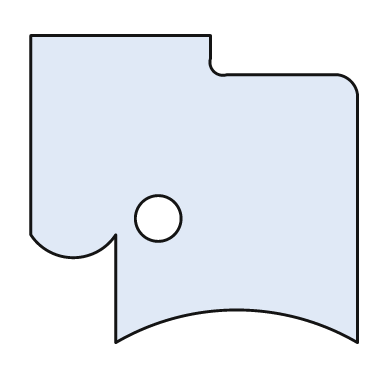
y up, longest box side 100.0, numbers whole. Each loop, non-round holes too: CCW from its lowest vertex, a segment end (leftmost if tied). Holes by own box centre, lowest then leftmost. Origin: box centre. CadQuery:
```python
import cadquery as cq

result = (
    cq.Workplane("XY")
    .moveTo(-24.0, -47.0)
    .threePointArc((13.0, -37.0), (50.0, -47.0))
    .lineTo(50.0, 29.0)
    .threePointArc((48.0, 33.0), (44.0, 35.0))
    .lineTo(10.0, 35.0)
    .threePointArc((6.0, 36.0), (5.0, 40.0))
    .lineTo(5.0, 47.0)
    .lineTo(-50.0, 47.0)
    .lineTo(-50.0, -14.0)
    .threePointArc((-37.0, -21.0), (-24.0, -14.0))
    .close()
    .moveTo(-11.0, -9.0)
    .circle(7.0)
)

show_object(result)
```